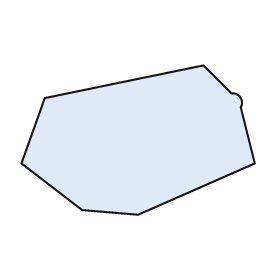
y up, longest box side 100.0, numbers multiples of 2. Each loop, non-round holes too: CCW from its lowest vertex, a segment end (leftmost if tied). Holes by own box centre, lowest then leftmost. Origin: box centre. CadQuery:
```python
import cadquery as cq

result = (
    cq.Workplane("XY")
    .moveTo(0.0, -32.0)
    .lineTo(50.0, -10.0)
    .lineTo(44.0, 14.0)
    .threePointArc((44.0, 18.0), (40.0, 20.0))
    .lineTo(28.0, 32.0)
    .lineTo(-40.0, 18.0)
    .lineTo(-50.0, -10.0)
    .lineTo(-24.0, -30.0)
    .close()
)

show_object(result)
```